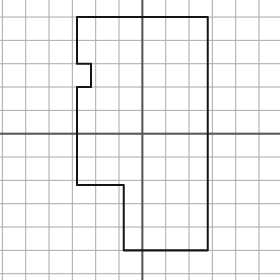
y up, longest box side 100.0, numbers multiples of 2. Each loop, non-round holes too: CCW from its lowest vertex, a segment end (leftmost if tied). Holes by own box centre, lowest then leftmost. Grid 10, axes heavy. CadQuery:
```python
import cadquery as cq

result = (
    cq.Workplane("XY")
    .moveTo(-8.0, -50.0)
    .lineTo(28.0, -50.0)
    .lineTo(28.0, 50.0)
    .lineTo(-28.0, 50.0)
    .lineTo(-28.0, 30.0)
    .lineTo(-22.0, 30.0)
    .lineTo(-22.0, 20.0)
    .lineTo(-28.0, 20.0)
    .lineTo(-28.0, -22.0)
    .lineTo(-8.0, -22.0)
    .close()
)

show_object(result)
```